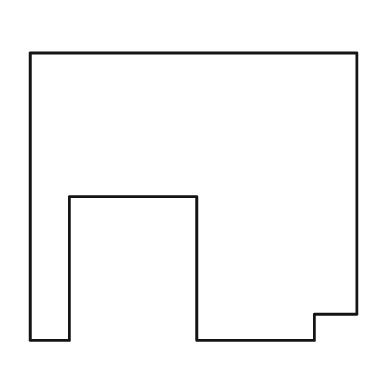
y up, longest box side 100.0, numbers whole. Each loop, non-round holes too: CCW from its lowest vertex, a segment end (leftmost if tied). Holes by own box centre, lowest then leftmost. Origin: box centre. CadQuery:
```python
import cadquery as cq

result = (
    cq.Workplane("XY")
    .moveTo(-50.0, -44.0)
    .lineTo(-38.0, -44.0)
    .lineTo(-38.0, 0.0)
    .lineTo(1.0, 0.0)
    .lineTo(1.0, -44.0)
    .lineTo(37.0, -44.0)
    .lineTo(37.0, -36.0)
    .lineTo(50.0, -36.0)
    .lineTo(50.0, 44.0)
    .lineTo(-50.0, 44.0)
    .close()
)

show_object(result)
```